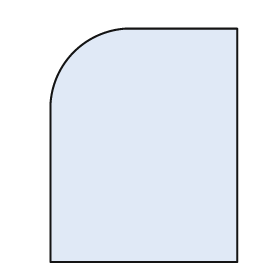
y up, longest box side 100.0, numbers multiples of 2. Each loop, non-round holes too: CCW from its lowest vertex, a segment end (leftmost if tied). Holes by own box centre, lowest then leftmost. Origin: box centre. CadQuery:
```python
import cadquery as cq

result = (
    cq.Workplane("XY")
    .moveTo(-40.0, -50.0)
    .lineTo(40.0, -50.0)
    .lineTo(40.0, 50.0)
    .lineTo(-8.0, 50.0)
    .threePointArc((-30.0, 40.0), (-40.0, 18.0))
    .close()
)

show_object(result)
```